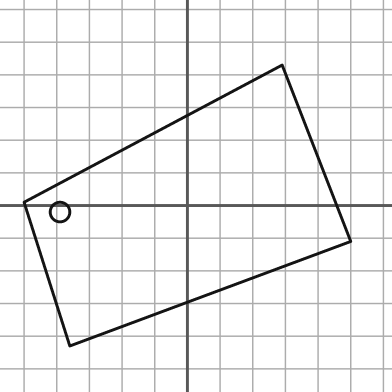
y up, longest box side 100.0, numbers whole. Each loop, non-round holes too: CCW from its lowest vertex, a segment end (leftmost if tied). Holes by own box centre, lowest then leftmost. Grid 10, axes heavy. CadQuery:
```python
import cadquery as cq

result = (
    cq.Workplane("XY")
    .moveTo(-36.0, -43.0)
    .lineTo(50.0, -11.0)
    .lineTo(29.0, 43.0)
    .lineTo(-50.0, 1.0)
    .close()
    .moveTo(-39.0, -2.0)
    .circle(3.0)
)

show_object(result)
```